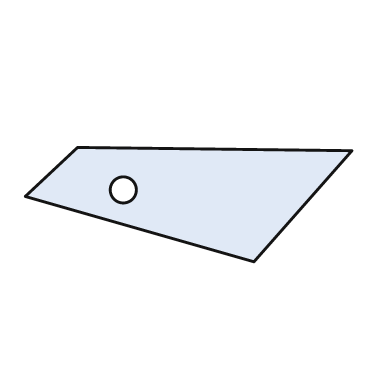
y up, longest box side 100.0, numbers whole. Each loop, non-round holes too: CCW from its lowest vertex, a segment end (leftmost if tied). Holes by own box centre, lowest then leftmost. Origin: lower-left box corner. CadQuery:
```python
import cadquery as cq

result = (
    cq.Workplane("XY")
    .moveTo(70.0, 0.0)
    .lineTo(100.0, 34.0)
    .lineTo(16.0, 35.0)
    .lineTo(0.0, 20.0)
    .close()
    .moveTo(30.0, 22.0)
    .circle(4.0)
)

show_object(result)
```